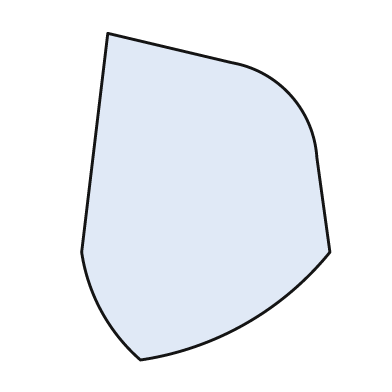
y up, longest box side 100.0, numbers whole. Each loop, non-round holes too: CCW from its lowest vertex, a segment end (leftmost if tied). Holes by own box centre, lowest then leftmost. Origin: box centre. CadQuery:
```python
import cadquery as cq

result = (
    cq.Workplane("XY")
    .moveTo(-20.0, -50.0)
    .threePointArc((12.0, -39.0), (38.0, -17.0))
    .lineTo(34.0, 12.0)
    .threePointArc((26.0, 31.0), (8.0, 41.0))
    .lineTo(-30.0, 50.0)
    .lineTo(-38.0, -17.0)
    .threePointArc((-32.0, -35.0), (-20.0, -50.0))
    .close()
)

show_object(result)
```